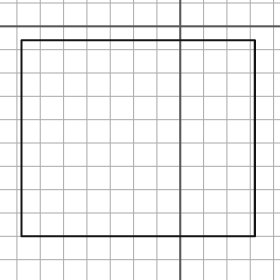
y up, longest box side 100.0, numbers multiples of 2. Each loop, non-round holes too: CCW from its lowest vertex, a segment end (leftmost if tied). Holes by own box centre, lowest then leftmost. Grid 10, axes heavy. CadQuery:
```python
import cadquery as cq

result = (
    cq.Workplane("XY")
    .moveTo(-68.0, -90.0)
    .lineTo(32.0, -90.0)
    .lineTo(32.0, -6.0)
    .lineTo(-68.0, -6.0)
    .close()
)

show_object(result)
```